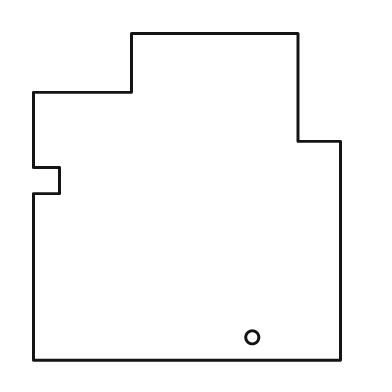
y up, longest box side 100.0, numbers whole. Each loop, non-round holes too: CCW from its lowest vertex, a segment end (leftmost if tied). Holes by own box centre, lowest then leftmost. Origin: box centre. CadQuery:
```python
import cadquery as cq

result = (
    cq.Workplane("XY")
    .moveTo(-47.0, -50.0)
    .lineTo(47.0, -50.0)
    .lineTo(47.0, 17.0)
    .lineTo(34.0, 17.0)
    .lineTo(34.0, 50.0)
    .lineTo(-17.0, 50.0)
    .lineTo(-17.0, 32.0)
    .lineTo(-47.0, 32.0)
    .lineTo(-47.0, 9.0)
    .lineTo(-39.0, 9.0)
    .lineTo(-39.0, 1.0)
    .lineTo(-47.0, 1.0)
    .close()
    .moveTo(20.0, -43.0)
    .circle(2.0)
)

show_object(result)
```